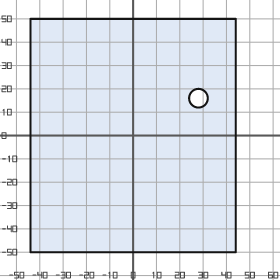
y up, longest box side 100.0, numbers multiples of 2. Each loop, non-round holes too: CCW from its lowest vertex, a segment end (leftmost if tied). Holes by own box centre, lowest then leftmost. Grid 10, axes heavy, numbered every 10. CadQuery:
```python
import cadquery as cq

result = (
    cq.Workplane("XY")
    .moveTo(-44.0, -50.0)
    .lineTo(44.0, -50.0)
    .lineTo(44.0, 50.0)
    .lineTo(-44.0, 50.0)
    .close()
    .moveTo(28.0, 16.0)
    .circle(4.0)
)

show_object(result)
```